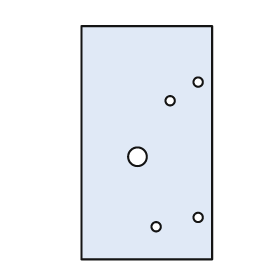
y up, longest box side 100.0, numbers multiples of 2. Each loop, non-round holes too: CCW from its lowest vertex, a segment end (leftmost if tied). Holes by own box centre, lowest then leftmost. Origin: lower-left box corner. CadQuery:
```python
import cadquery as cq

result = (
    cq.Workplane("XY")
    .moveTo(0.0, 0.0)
    .lineTo(56.0, 0.0)
    .lineTo(56.0, 100.0)
    .lineTo(0.0, 100.0)
    .close()
    .moveTo(32.0, 14.0)
    .circle(2.0)
    .moveTo(50.0, 18.0)
    .circle(2.0)
    .moveTo(24.0, 44.0)
    .circle(4.0)
    .moveTo(38.0, 68.0)
    .circle(2.0)
    .moveTo(50.0, 76.0)
    .circle(2.0)
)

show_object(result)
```